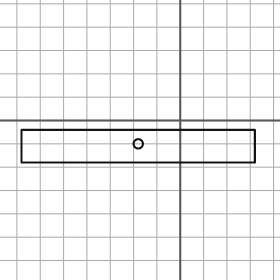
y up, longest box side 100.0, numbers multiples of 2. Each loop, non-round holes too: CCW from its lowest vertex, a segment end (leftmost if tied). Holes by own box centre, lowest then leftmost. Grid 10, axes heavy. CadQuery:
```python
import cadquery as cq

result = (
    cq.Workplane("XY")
    .moveTo(-68.0, -18.0)
    .lineTo(32.0, -18.0)
    .lineTo(32.0, -4.0)
    .lineTo(-68.0, -4.0)
    .close()
    .moveTo(-18.0, -10.0)
    .circle(2.0)
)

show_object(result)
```